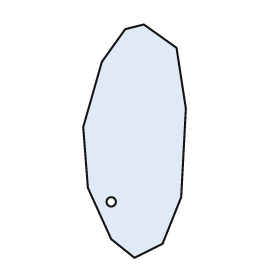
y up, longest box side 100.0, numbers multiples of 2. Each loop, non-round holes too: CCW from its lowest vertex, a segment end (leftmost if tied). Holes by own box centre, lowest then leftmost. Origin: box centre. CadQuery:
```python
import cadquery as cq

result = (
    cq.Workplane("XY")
    .moveTo(0.0, -50.0)
    .lineTo(12.0, -44.0)
    .lineTo(20.0, -24.0)
    .lineTo(22.0, 14.0)
    .lineTo(18.0, 40.0)
    .lineTo(4.0, 50.0)
    .lineTo(-4.0, 48.0)
    .lineTo(-14.0, 34.0)
    .lineTo(-22.0, 6.0)
    .lineTo(-20.0, -20.0)
    .lineTo(-10.0, -42.0)
    .close()
    .moveTo(-10.0, -26.0)
    .circle(2.0)
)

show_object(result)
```